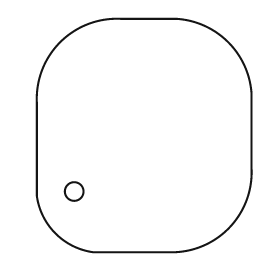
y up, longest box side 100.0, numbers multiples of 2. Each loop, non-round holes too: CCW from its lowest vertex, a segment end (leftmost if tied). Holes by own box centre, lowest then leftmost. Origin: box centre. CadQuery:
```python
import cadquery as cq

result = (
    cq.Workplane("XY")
    .moveTo(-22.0, -50.0)
    .lineTo(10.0, -50.0)
    .threePointArc((36.0, -40.0), (46.0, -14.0))
    .lineTo(46.0, 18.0)
    .threePointArc((36.0, 40.0), (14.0, 50.0))
    .lineTo(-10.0, 50.0)
    .threePointArc((-36.0, 40.0), (-46.0, 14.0))
    .lineTo(-46.0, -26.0)
    .threePointArc((-38.0, -42.0), (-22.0, -50.0))
    .close()
    .moveTo(-30.0, -24.0)
    .circle(4.0)
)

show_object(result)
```